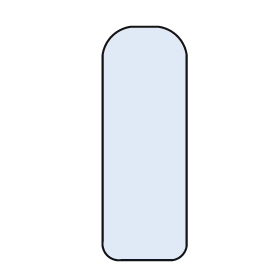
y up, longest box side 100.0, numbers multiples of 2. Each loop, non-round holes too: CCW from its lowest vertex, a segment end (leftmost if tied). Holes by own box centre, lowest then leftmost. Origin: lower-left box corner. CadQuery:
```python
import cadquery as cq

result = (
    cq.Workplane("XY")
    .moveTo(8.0, 0.0)
    .lineTo(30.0, 0.0)
    .threePointArc((34.0, 2.0), (36.0, 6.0))
    .lineTo(36.0, 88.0)
    .threePointArc((32.0, 96.0), (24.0, 100.0))
    .lineTo(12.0, 100.0)
    .threePointArc((4.0, 96.0), (0.0, 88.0))
    .lineTo(0.0, 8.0)
    .threePointArc((2.0, 2.0), (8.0, 0.0))
    .close()
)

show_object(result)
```